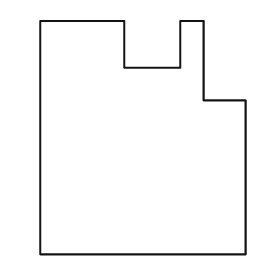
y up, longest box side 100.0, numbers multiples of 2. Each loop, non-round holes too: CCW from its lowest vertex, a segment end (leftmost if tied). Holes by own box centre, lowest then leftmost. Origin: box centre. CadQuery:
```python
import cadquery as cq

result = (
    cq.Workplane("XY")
    .moveTo(-44.0, -50.0)
    .lineTo(44.0, -50.0)
    .lineTo(44.0, 16.0)
    .lineTo(26.0, 16.0)
    .lineTo(26.0, 50.0)
    .lineTo(16.0, 50.0)
    .lineTo(16.0, 30.0)
    .lineTo(-8.0, 30.0)
    .lineTo(-8.0, 50.0)
    .lineTo(-44.0, 50.0)
    .close()
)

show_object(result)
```